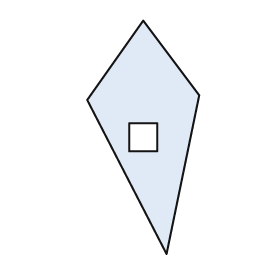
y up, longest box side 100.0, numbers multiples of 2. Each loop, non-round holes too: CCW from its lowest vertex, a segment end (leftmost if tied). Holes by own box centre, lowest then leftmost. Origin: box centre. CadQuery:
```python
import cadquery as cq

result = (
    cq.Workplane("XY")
    .moveTo(10.0, -50.0)
    .lineTo(24.0, 18.0)
    .lineTo(0.0, 50.0)
    .lineTo(-24.0, 16.0)
    .close()
    .moveTo(-6.0, -6.0)
    .lineTo(6.0, -6.0)
    .lineTo(6.0, 6.0)
    .lineTo(-6.0, 6.0)
    .close()
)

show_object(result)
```